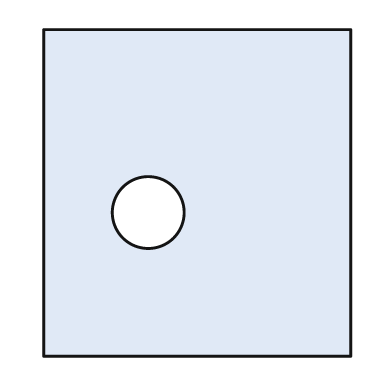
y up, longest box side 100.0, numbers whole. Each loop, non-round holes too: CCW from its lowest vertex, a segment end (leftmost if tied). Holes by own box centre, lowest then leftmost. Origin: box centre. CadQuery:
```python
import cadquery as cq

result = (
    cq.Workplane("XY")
    .moveTo(-47.0, -50.0)
    .lineTo(47.0, -50.0)
    .lineTo(47.0, 50.0)
    .lineTo(-47.0, 50.0)
    .close()
    .moveTo(-15.0, -6.0)
    .circle(11.0)
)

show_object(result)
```